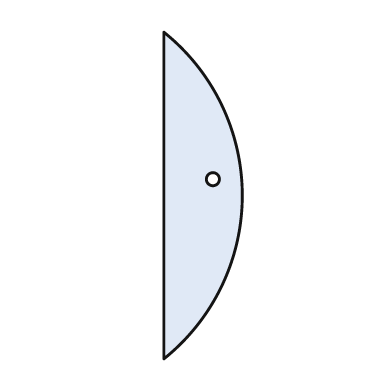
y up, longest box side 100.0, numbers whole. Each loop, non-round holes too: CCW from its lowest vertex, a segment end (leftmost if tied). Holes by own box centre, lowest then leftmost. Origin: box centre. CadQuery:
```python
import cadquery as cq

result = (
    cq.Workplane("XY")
    .moveTo(-12.0, -50.0)
    .threePointArc((12.0, 0.0), (-12.0, 50.0))
    .close()
    .moveTo(3.0, 5.0)
    .circle(2.0)
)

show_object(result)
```